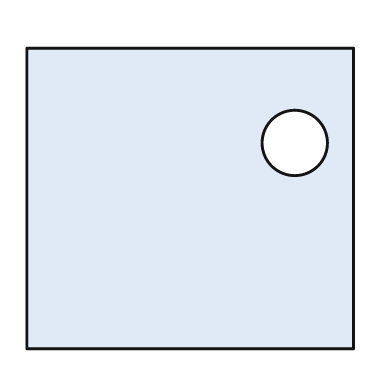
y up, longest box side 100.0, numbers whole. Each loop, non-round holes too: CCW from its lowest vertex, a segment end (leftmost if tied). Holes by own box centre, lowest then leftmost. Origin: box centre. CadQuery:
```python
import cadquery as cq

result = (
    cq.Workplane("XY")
    .moveTo(-50.0, -46.0)
    .lineTo(50.0, -46.0)
    .lineTo(50.0, 46.0)
    .lineTo(-50.0, 46.0)
    .close()
    .moveTo(32.0, 17.0)
    .circle(10.0)
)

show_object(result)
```